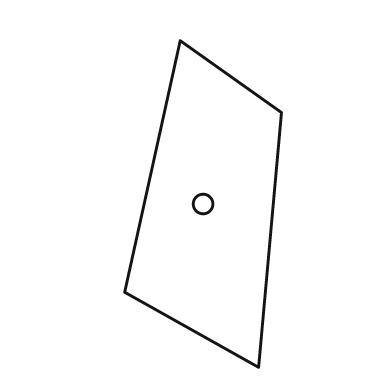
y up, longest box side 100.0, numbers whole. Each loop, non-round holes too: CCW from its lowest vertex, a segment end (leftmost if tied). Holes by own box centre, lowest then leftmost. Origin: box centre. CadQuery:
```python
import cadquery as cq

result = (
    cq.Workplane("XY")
    .moveTo(17.0, -50.0)
    .lineTo(24.0, 28.0)
    .lineTo(-7.0, 50.0)
    .lineTo(-24.0, -27.0)
    .close()
    .moveTo(0.0, 0.0)
    .circle(3.0)
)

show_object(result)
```